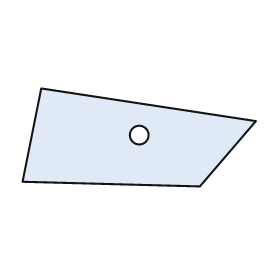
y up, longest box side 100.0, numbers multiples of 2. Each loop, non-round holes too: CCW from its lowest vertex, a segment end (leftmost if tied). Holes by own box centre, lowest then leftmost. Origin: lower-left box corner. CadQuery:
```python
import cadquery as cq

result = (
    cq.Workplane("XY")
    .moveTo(76.0, 0.0)
    .lineTo(100.0, 28.0)
    .lineTo(8.0, 42.0)
    .lineTo(0.0, 2.0)
    .close()
    .moveTo(50.0, 22.0)
    .circle(4.0)
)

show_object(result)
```